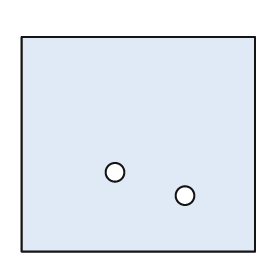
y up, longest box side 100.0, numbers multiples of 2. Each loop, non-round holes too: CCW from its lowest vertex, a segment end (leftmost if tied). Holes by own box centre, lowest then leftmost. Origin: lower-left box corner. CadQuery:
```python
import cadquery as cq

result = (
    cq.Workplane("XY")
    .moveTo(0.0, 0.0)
    .lineTo(100.0, 0.0)
    .lineTo(100.0, 92.0)
    .lineTo(0.0, 92.0)
    .close()
    .moveTo(70.0, 24.0)
    .circle(4.0)
    .moveTo(40.0, 34.0)
    .circle(4.0)
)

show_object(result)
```